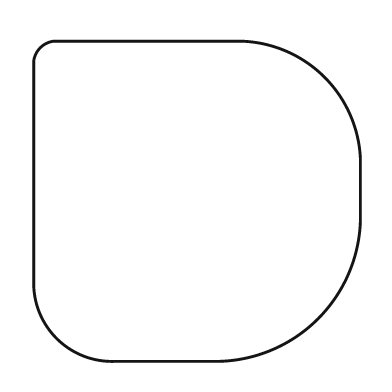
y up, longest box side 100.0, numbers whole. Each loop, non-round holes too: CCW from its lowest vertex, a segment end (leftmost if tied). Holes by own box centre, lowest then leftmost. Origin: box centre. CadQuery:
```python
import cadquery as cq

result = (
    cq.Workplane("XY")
    .moveTo(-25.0, -49.0)
    .lineTo(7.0, -49.0)
    .threePointArc((37.0, -36.0), (50.0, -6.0))
    .lineTo(50.0, 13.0)
    .threePointArc((39.0, 38.0), (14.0, 49.0))
    .lineTo(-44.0, 49.0)
    .threePointArc((-48.0, 47.0), (-50.0, 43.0))
    .lineTo(-50.0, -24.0)
    .threePointArc((-43.0, -42.0), (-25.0, -49.0))
    .close()
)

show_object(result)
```